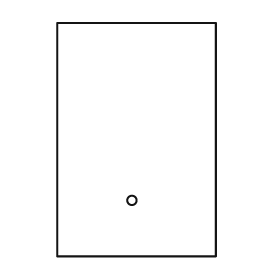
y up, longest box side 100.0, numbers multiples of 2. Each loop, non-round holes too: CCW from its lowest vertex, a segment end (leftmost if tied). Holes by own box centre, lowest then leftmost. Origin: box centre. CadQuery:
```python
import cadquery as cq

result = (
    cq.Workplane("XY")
    .moveTo(-34.0, -50.0)
    .lineTo(34.0, -50.0)
    .lineTo(34.0, 50.0)
    .lineTo(-34.0, 50.0)
    .close()
    .moveTo(-2.0, -26.0)
    .circle(2.0)
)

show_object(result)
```